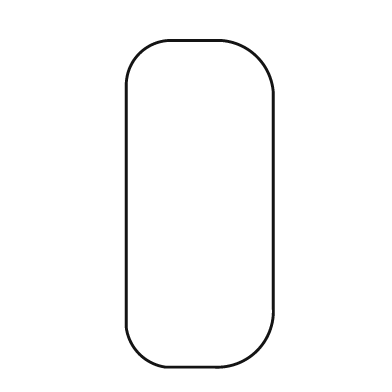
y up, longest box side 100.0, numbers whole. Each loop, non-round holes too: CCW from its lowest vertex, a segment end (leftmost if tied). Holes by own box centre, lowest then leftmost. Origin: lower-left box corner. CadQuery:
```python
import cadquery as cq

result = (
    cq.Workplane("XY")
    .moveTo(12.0, 0.0)
    .lineTo(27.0, 0.0)
    .threePointArc((40.0, 5.0), (45.0, 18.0))
    .lineTo(45.0, 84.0)
    .threePointArc((40.0, 95.0), (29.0, 100.0))
    .lineTo(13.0, 100.0)
    .threePointArc((4.0, 96.0), (0.0, 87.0))
    .lineTo(0.0, 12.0)
    .threePointArc((4.0, 4.0), (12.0, 0.0))
    .close()
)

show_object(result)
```